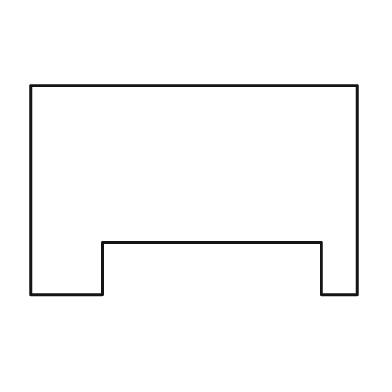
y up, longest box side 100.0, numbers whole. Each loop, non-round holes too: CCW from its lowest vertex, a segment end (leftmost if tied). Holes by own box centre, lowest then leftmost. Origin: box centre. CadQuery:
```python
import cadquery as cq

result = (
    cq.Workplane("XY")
    .moveTo(-50.0, -32.0)
    .lineTo(-28.0, -32.0)
    .lineTo(-28.0, -16.0)
    .lineTo(39.0, -16.0)
    .lineTo(39.0, -32.0)
    .lineTo(50.0, -32.0)
    .lineTo(50.0, 32.0)
    .lineTo(-50.0, 32.0)
    .close()
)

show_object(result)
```